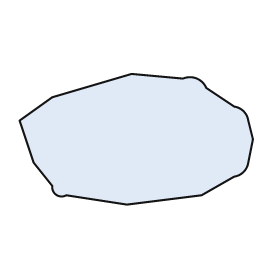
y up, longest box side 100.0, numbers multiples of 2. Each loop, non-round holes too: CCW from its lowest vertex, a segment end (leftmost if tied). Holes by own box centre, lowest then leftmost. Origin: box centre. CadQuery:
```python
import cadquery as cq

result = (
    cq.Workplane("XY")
    .moveTo(-4.0, -28.0)
    .lineTo(28.0, -24.0)
    .lineTo(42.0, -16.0)
    .threePointArc((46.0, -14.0), (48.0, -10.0))
    .lineTo(50.0, 0.0)
    .lineTo(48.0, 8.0)
    .threePointArc((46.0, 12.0), (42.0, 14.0))
    .lineTo(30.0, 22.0)
    .threePointArc((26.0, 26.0), (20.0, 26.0))
    .lineTo(-2.0, 28.0)
    .lineTo(-36.0, 18.0)
    .lineTo(-50.0, 8.0)
    .lineTo(-44.0, -10.0)
    .lineTo(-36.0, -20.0)
    .threePointArc((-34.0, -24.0), (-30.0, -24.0))
    .close()
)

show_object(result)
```